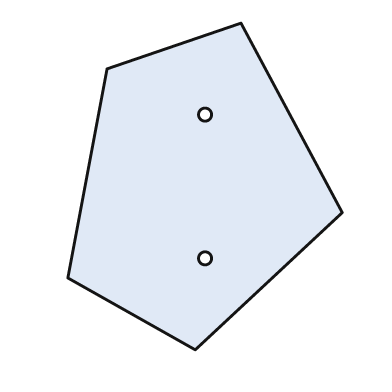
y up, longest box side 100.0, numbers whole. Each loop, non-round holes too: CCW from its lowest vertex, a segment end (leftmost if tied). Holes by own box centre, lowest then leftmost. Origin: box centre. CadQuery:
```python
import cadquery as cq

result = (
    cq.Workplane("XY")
    .moveTo(-3.0, -50.0)
    .lineTo(42.0, -8.0)
    .lineTo(11.0, 50.0)
    .lineTo(-30.0, 36.0)
    .lineTo(-42.0, -28.0)
    .close()
    .moveTo(0.0, -22.0)
    .circle(2.0)
    .moveTo(0.0, 22.0)
    .circle(2.0)
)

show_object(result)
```